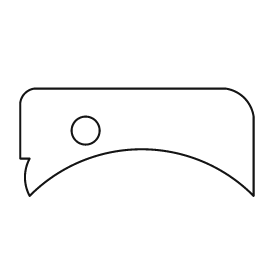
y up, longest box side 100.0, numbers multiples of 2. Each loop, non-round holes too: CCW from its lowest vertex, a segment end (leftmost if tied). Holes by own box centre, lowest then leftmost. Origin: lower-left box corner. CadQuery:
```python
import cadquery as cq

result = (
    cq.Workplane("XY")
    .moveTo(4.0, 0.0)
    .threePointArc((52.0, 20.0), (100.0, 0.0))
    .lineTo(100.0, 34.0)
    .threePointArc((96.0, 42.0), (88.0, 46.0))
    .lineTo(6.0, 46.0)
    .threePointArc((2.0, 44.0), (0.0, 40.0))
    .lineTo(0.0, 16.0)
    .lineTo(4.0, 16.0)
    .threePointArc((2.0, 8.0), (4.0, 0.0))
    .close()
    .moveTo(28.0, 28.0)
    .circle(6.0)
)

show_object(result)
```